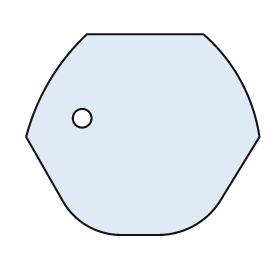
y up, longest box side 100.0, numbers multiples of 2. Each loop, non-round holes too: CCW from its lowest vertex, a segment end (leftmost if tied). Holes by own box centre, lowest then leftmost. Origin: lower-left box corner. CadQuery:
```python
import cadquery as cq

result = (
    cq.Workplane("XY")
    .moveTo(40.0, 0.0)
    .lineTo(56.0, 0.0)
    .threePointArc((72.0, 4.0), (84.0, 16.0))
    .lineTo(100.0, 42.0)
    .threePointArc((92.0, 66.0), (76.0, 86.0))
    .lineTo(26.0, 86.0)
    .threePointArc((10.0, 66.0), (0.0, 42.0))
    .lineTo(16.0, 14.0)
    .threePointArc((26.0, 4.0), (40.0, 0.0))
    .close()
    .moveTo(24.0, 50.0)
    .circle(4.0)
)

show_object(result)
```